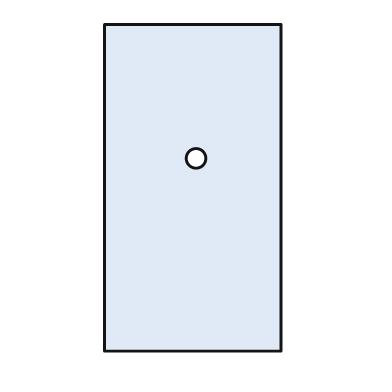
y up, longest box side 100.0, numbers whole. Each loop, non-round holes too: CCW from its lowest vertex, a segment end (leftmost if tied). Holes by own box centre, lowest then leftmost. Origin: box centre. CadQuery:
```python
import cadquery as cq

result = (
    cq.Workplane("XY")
    .moveTo(-27.0, -50.0)
    .lineTo(27.0, -50.0)
    .lineTo(27.0, 50.0)
    .lineTo(-27.0, 50.0)
    .close()
    .moveTo(1.0, 9.0)
    .circle(3.0)
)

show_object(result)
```